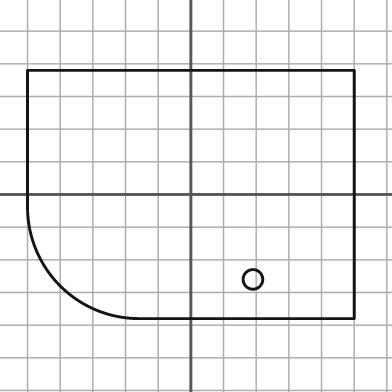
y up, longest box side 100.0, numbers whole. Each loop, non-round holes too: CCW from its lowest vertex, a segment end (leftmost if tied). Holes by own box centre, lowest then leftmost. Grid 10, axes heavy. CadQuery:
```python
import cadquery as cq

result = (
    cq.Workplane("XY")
    .moveTo(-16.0, -38.0)
    .lineTo(50.0, -38.0)
    .lineTo(50.0, 38.0)
    .lineTo(-50.0, 38.0)
    .lineTo(-50.0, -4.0)
    .threePointArc((-40.0, -28.0), (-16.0, -38.0))
    .close()
    .moveTo(19.0, -26.0)
    .circle(3.0)
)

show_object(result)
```